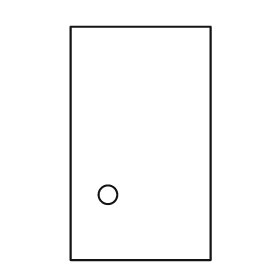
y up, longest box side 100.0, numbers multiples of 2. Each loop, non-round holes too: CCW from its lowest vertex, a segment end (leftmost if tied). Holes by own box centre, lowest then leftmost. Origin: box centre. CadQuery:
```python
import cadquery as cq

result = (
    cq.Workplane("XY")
    .moveTo(-30.0, -50.0)
    .lineTo(30.0, -50.0)
    .lineTo(30.0, 50.0)
    .lineTo(-30.0, 50.0)
    .close()
    .moveTo(-14.0, -22.0)
    .circle(4.0)
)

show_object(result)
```